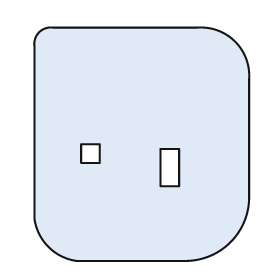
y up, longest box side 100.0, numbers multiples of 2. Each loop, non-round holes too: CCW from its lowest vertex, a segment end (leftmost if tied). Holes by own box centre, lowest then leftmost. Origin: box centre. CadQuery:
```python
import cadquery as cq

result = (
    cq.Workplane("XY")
    .moveTo(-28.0, -50.0)
    .lineTo(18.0, -50.0)
    .threePointArc((38.0, -42.0), (46.0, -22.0))
    .lineTo(46.0, 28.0)
    .threePointArc((40.0, 44.0), (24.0, 50.0))
    .lineTo(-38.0, 50.0)
    .threePointArc((-44.0, 48.0), (-46.0, 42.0))
    .lineTo(-46.0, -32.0)
    .threePointArc((-40.0, -44.0), (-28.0, -50.0))
    .close()
    .moveTo(8.0, -18.0)
    .lineTo(16.0, -18.0)
    .lineTo(16.0, -2.0)
    .lineTo(8.0, -2.0)
    .close()
    .moveTo(-26.0, -8.0)
    .lineTo(-18.0, -8.0)
    .lineTo(-18.0, 0.0)
    .lineTo(-26.0, 0.0)
    .close()
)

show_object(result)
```